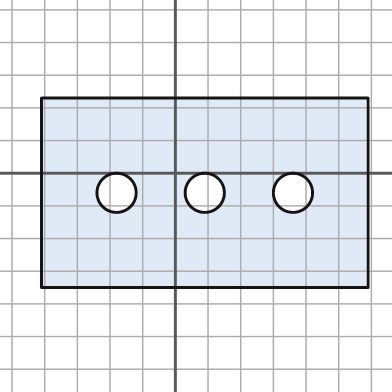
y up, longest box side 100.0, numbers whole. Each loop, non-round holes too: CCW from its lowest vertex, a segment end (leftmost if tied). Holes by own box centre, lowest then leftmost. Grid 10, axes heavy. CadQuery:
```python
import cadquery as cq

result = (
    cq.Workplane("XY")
    .moveTo(-41.0, -35.0)
    .lineTo(59.0, -35.0)
    .lineTo(59.0, 23.0)
    .lineTo(-41.0, 23.0)
    .close()
    .moveTo(-18.0, -6.0)
    .circle(6.0)
    .moveTo(9.0, -6.0)
    .circle(6.0)
    .moveTo(36.0, -6.0)
    .circle(6.0)
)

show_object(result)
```